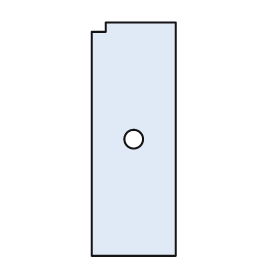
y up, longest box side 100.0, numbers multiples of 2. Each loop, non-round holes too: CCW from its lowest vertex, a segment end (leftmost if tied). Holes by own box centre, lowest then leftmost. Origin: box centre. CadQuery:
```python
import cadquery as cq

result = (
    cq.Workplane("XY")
    .moveTo(-18.0, -50.0)
    .lineTo(18.0, -50.0)
    .lineTo(18.0, 50.0)
    .lineTo(-12.0, 50.0)
    .lineTo(-12.0, 46.0)
    .lineTo(-18.0, 46.0)
    .close()
    .moveTo(0.0, 0.0)
    .circle(4.0)
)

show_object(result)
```